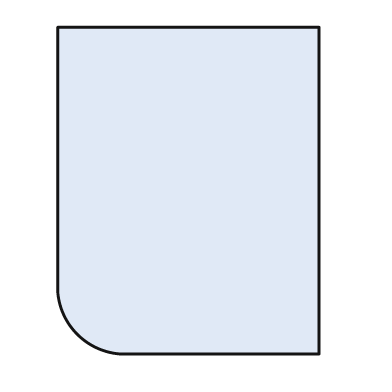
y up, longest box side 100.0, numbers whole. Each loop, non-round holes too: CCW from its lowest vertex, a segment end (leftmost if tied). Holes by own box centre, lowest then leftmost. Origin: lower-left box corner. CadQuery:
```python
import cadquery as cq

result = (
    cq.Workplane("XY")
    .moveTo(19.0, 0.0)
    .lineTo(80.0, 0.0)
    .lineTo(80.0, 100.0)
    .lineTo(0.0, 100.0)
    .lineTo(0.0, 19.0)
    .threePointArc((6.0, 6.0), (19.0, 0.0))
    .close()
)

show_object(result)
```